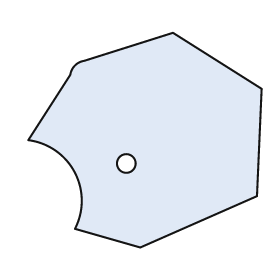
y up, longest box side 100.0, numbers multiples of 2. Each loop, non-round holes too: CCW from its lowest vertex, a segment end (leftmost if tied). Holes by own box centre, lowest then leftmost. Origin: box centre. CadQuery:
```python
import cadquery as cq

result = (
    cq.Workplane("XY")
    .moveTo(-2.0, -46.0)
    .lineTo(48.0, -24.0)
    .lineTo(50.0, 22.0)
    .lineTo(12.0, 46.0)
    .lineTo(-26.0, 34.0)
    .threePointArc((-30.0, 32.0), (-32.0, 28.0))
    .lineTo(-50.0, 0.0)
    .threePointArc((-30.0, -14.0), (-30.0, -38.0))
    .close()
    .moveTo(-8.0, -10.0)
    .circle(4.0)
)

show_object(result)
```